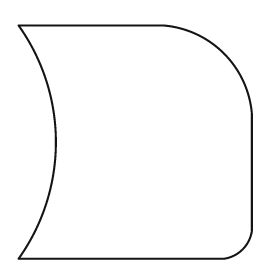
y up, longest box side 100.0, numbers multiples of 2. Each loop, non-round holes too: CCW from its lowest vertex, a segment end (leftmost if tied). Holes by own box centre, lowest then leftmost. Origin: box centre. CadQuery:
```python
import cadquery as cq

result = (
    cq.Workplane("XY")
    .moveTo(-50.0, -50.0)
    .lineTo(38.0, -50.0)
    .threePointArc((46.0, -46.0), (50.0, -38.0))
    .lineTo(50.0, 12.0)
    .threePointArc((38.0, 38.0), (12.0, 50.0))
    .lineTo(-50.0, 50.0)
    .threePointArc((-34.0, 0.0), (-50.0, -50.0))
    .close()
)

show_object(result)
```